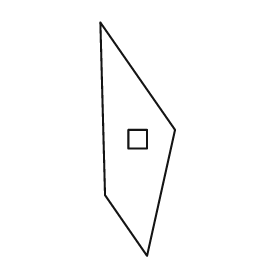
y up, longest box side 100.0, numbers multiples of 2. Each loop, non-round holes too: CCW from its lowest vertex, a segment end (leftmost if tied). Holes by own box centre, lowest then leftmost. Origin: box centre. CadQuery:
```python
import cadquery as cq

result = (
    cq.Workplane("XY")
    .moveTo(4.0, -50.0)
    .lineTo(16.0, 4.0)
    .lineTo(-16.0, 50.0)
    .lineTo(-14.0, -24.0)
    .close()
    .moveTo(-4.0, -4.0)
    .lineTo(4.0, -4.0)
    .lineTo(4.0, 4.0)
    .lineTo(-4.0, 4.0)
    .close()
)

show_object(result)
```